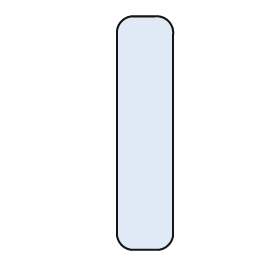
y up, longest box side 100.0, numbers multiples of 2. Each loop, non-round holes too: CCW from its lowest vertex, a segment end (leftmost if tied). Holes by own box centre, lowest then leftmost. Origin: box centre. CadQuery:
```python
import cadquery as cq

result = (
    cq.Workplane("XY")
    .moveTo(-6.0, -50.0)
    .lineTo(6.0, -50.0)
    .threePointArc((10.0, -48.0), (12.0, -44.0))
    .lineTo(12.0, 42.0)
    .threePointArc((10.0, 48.0), (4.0, 50.0))
    .lineTo(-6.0, 50.0)
    .threePointArc((-10.0, 48.0), (-12.0, 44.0))
    .lineTo(-12.0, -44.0)
    .threePointArc((-10.0, -48.0), (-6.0, -50.0))
    .close()
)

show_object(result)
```